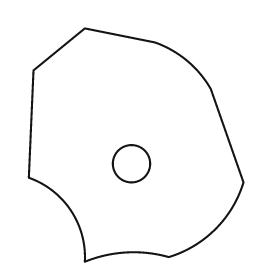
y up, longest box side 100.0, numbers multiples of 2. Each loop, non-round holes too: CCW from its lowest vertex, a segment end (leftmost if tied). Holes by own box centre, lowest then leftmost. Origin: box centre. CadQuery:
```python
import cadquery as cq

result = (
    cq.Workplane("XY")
    .moveTo(-22.0, -50.0)
    .threePointArc((-4.0, -46.0), (14.0, -48.0))
    .threePointArc((34.0, -36.0), (46.0, -16.0))
    .lineTo(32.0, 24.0)
    .threePointArc((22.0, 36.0), (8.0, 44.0))
    .lineTo(-22.0, 50.0)
    .lineTo(-44.0, 32.0)
    .lineTo(-46.0, -14.0)
    .threePointArc((-28.0, -28.0), (-22.0, -50.0))
    .close()
    .moveTo(-2.0, -8.0)
    .circle(8.0)
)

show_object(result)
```